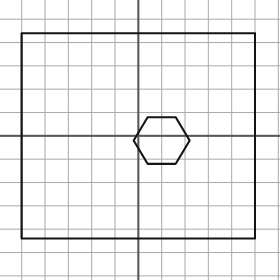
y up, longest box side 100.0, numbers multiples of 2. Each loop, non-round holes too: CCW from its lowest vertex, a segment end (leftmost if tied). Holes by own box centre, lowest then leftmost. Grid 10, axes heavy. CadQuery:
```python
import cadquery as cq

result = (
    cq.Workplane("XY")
    .moveTo(-50.0, -44.0)
    .lineTo(50.0, -44.0)
    .lineTo(50.0, 44.0)
    .lineTo(-50.0, 44.0)
    .close()
    .moveTo(4.0, -12.0)
    .lineTo(16.0, -12.0)
    .lineTo(22.0, -2.0)
    .lineTo(16.0, 8.0)
    .lineTo(4.0, 8.0)
    .lineTo(-2.0, -2.0)
    .close()
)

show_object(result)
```